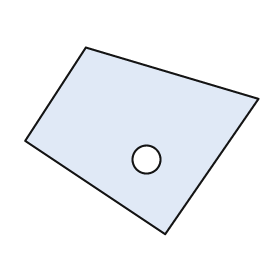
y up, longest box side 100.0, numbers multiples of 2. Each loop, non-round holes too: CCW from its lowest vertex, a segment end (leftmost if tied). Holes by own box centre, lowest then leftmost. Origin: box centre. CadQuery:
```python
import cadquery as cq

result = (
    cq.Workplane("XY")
    .moveTo(10.0, -40.0)
    .lineTo(50.0, 18.0)
    .lineTo(-24.0, 40.0)
    .lineTo(-50.0, 0.0)
    .close()
    .moveTo(2.0, -8.0)
    .circle(6.0)
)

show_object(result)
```